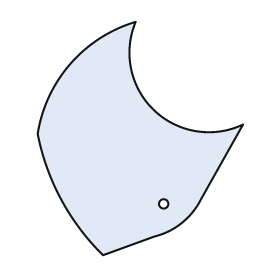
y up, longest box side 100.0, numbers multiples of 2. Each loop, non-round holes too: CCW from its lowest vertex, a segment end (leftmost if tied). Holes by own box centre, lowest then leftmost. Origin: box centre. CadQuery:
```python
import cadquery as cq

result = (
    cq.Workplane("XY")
    .moveTo(-16.0, -50.0)
    .lineTo(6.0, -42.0)
    .threePointArc((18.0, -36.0), (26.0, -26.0))
    .lineTo(44.0, 6.0)
    .threePointArc((6.0, 12.0), (-2.0, 50.0))
    .threePointArc((-30.0, 32.0), (-44.0, 2.0))
    .threePointArc((-34.0, -26.0), (-16.0, -50.0))
    .close()
    .moveTo(10.0, -28.0)
    .circle(2.0)
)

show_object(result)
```